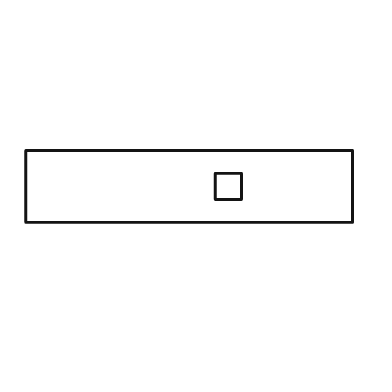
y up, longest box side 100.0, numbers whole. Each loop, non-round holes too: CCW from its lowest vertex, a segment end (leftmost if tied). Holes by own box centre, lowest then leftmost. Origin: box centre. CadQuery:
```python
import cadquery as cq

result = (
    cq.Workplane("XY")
    .moveTo(-50.0, -11.0)
    .lineTo(50.0, -11.0)
    .lineTo(50.0, 11.0)
    .lineTo(-50.0, 11.0)
    .close()
    .moveTo(8.0, -4.0)
    .lineTo(16.0, -4.0)
    .lineTo(16.0, 4.0)
    .lineTo(8.0, 4.0)
    .close()
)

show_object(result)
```